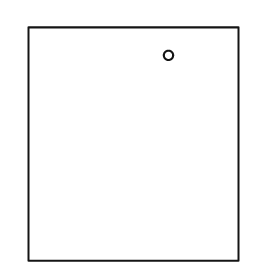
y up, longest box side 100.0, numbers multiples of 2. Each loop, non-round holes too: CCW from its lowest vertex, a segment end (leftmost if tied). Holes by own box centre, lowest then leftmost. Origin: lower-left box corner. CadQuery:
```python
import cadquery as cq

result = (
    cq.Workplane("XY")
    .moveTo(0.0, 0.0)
    .lineTo(90.0, 0.0)
    .lineTo(90.0, 100.0)
    .lineTo(0.0, 100.0)
    .close()
    .moveTo(60.0, 88.0)
    .circle(2.0)
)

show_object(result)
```